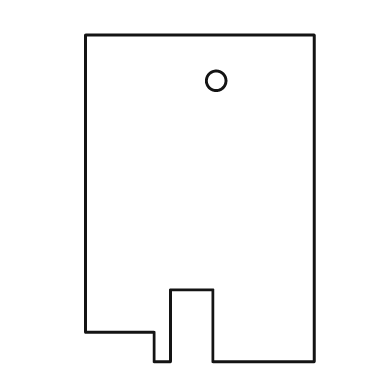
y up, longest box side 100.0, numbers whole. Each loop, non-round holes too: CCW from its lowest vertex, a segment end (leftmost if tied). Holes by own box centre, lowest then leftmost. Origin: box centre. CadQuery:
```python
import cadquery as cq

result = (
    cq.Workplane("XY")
    .moveTo(-14.0, -50.0)
    .lineTo(-9.0, -50.0)
    .lineTo(-9.0, -28.0)
    .lineTo(4.0, -28.0)
    .lineTo(4.0, -50.0)
    .lineTo(35.0, -50.0)
    .lineTo(35.0, 50.0)
    .lineTo(-35.0, 50.0)
    .lineTo(-35.0, -41.0)
    .lineTo(-14.0, -41.0)
    .close()
    .moveTo(5.0, 36.0)
    .circle(3.0)
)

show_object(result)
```